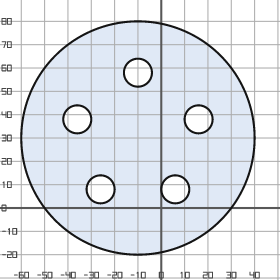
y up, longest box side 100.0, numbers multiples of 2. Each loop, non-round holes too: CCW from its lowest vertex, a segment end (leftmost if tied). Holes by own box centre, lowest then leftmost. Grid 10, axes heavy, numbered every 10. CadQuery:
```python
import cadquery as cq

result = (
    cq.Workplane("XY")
    .moveTo(-10.0, 30.0)
    .circle(50.0)
    .moveTo(-26.0, 8.0)
    .circle(6.0)
    .moveTo(6.0, 8.0)
    .circle(6.0)
    .moveTo(-36.0, 38.0)
    .circle(6.0)
    .moveTo(16.0, 38.0)
    .circle(6.0)
    .moveTo(-10.0, 58.0)
    .circle(6.0)
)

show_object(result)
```